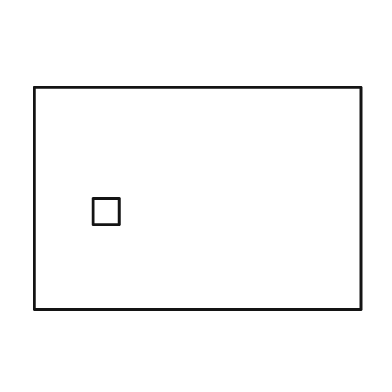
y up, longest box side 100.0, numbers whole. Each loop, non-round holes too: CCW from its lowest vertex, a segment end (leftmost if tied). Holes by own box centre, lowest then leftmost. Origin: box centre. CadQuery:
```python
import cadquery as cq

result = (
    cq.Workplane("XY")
    .moveTo(-50.0, -34.0)
    .lineTo(50.0, -34.0)
    .lineTo(50.0, 34.0)
    .lineTo(-50.0, 34.0)
    .close()
    .moveTo(-32.0, -8.0)
    .lineTo(-24.0, -8.0)
    .lineTo(-24.0, 0.0)
    .lineTo(-32.0, 0.0)
    .close()
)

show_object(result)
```